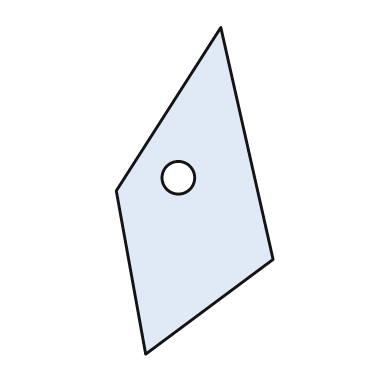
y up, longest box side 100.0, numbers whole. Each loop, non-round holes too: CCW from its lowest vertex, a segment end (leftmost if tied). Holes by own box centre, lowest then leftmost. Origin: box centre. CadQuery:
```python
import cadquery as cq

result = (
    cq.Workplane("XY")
    .moveTo(-15.0, -50.0)
    .lineTo(24.0, -21.0)
    .lineTo(8.0, 50.0)
    .lineTo(-24.0, 0.0)
    .close()
    .moveTo(-5.0, 4.0)
    .circle(5.0)
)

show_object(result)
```